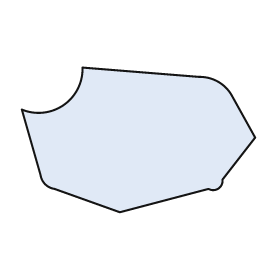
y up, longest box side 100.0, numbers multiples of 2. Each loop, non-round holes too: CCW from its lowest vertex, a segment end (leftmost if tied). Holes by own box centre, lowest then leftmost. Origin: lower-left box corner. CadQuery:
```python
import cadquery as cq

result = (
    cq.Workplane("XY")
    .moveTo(42.0, 0.0)
    .lineTo(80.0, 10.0)
    .threePointArc((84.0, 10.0), (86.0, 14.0))
    .lineTo(100.0, 32.0)
    .lineTo(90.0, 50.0)
    .threePointArc((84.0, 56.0), (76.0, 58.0))
    .lineTo(26.0, 62.0)
    .threePointArc((18.0, 46.0), (0.0, 44.0))
    .lineTo(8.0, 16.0)
    .threePointArc((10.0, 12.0), (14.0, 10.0))
    .close()
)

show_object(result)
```